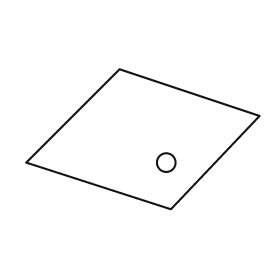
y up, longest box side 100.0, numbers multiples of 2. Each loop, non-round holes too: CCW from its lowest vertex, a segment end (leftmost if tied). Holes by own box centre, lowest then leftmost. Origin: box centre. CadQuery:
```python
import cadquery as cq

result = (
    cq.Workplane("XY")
    .moveTo(12.0, -30.0)
    .lineTo(50.0, 10.0)
    .lineTo(-10.0, 30.0)
    .lineTo(-50.0, -10.0)
    .close()
    .moveTo(10.0, -10.0)
    .circle(4.0)
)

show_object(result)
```